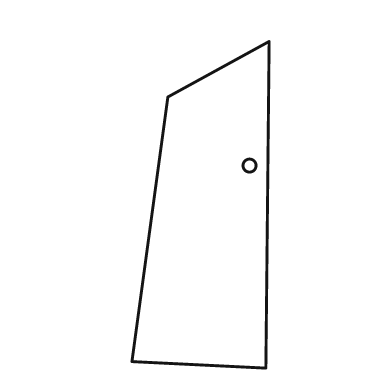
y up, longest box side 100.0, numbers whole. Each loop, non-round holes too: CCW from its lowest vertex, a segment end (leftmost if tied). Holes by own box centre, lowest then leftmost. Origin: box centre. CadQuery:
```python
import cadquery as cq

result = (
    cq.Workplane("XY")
    .moveTo(20.0, -50.0)
    .lineTo(21.0, 50.0)
    .lineTo(-10.0, 33.0)
    .lineTo(-21.0, -48.0)
    .close()
    .moveTo(15.0, 12.0)
    .circle(2.0)
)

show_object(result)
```